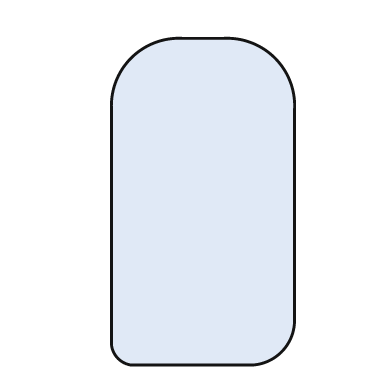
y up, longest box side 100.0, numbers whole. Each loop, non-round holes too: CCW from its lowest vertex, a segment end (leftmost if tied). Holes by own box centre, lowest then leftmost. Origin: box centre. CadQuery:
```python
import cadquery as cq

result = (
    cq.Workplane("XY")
    .moveTo(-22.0, -50.0)
    .lineTo(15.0, -50.0)
    .threePointArc((24.0, -46.0), (28.0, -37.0))
    .lineTo(28.0, 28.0)
    .threePointArc((22.0, 44.0), (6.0, 50.0))
    .lineTo(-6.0, 50.0)
    .threePointArc((-22.0, 44.0), (-28.0, 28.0))
    .lineTo(-28.0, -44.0)
    .threePointArc((-26.0, -48.0), (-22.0, -50.0))
    .close()
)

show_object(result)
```